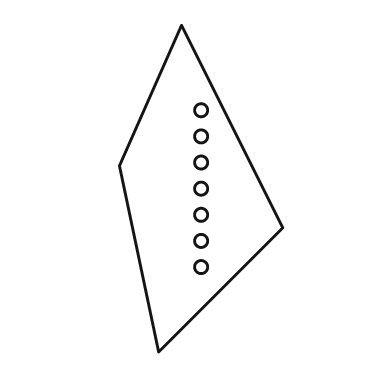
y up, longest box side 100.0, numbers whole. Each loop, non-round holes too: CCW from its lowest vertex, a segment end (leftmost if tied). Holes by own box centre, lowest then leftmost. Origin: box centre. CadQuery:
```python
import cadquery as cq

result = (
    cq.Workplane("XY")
    .moveTo(-13.0, -50.0)
    .lineTo(25.0, -12.0)
    .lineTo(-6.0, 50.0)
    .lineTo(-25.0, 7.0)
    .close()
    .moveTo(0.0, -24.0)
    .circle(2.0)
    .moveTo(0.0, -16.0)
    .circle(2.0)
    .moveTo(0.0, -8.0)
    .circle(2.0)
    .moveTo(0.0, 0.0)
    .circle(2.0)
    .moveTo(0.0, 8.0)
    .circle(2.0)
    .moveTo(0.0, 16.0)
    .circle(2.0)
    .moveTo(0.0, 24.0)
    .circle(2.0)
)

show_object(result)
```